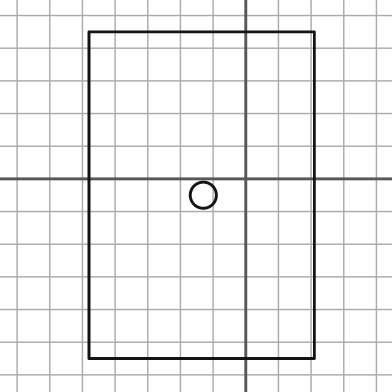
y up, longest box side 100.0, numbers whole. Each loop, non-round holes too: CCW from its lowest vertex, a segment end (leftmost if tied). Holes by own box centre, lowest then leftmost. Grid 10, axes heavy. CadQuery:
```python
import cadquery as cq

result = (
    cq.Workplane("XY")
    .moveTo(-48.0, -55.0)
    .lineTo(21.0, -55.0)
    .lineTo(21.0, 45.0)
    .lineTo(-48.0, 45.0)
    .close()
    .moveTo(-13.0, -5.0)
    .circle(4.0)
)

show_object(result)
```